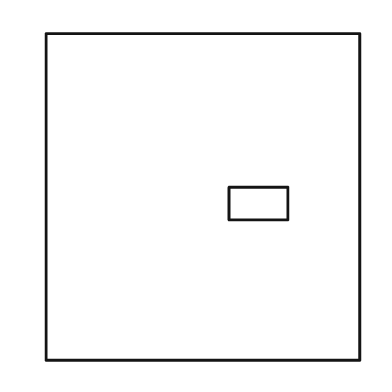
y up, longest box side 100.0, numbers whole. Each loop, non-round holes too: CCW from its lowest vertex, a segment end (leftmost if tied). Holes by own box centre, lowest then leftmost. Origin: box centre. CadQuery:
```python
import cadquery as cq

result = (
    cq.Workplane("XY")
    .moveTo(-48.0, -50.0)
    .lineTo(48.0, -50.0)
    .lineTo(48.0, 50.0)
    .lineTo(-48.0, 50.0)
    .close()
    .moveTo(8.0, -7.0)
    .lineTo(26.0, -7.0)
    .lineTo(26.0, 3.0)
    .lineTo(8.0, 3.0)
    .close()
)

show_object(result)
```